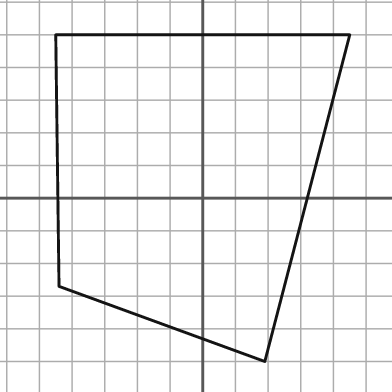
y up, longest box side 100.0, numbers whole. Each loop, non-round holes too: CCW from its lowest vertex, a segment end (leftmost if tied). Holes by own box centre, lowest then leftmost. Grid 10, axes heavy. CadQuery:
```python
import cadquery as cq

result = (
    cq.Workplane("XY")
    .moveTo(19.0, -50.0)
    .lineTo(45.0, 50.0)
    .lineTo(-45.0, 50.0)
    .lineTo(-44.0, -27.0)
    .close()
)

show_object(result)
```